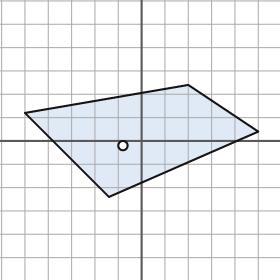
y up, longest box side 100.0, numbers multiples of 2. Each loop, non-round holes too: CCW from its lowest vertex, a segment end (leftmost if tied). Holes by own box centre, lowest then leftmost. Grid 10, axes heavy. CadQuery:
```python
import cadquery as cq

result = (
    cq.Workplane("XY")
    .moveTo(-14.0, -24.0)
    .lineTo(50.0, 4.0)
    .lineTo(20.0, 24.0)
    .lineTo(-50.0, 12.0)
    .close()
    .moveTo(-8.0, -2.0)
    .circle(2.0)
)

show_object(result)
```